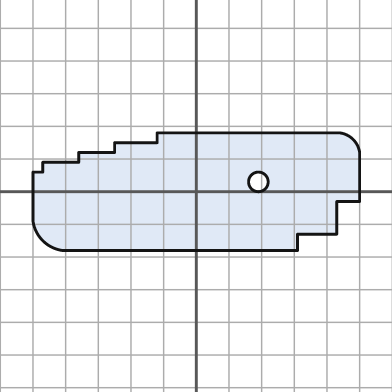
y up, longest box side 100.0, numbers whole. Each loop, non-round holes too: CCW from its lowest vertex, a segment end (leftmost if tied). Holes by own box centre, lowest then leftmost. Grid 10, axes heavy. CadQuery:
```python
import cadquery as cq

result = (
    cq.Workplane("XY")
    .moveTo(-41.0, -18.0)
    .lineTo(31.0, -18.0)
    .lineTo(31.0, -13.0)
    .lineTo(43.0, -13.0)
    .lineTo(43.0, -3.0)
    .lineTo(50.0, -3.0)
    .lineTo(50.0, 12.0)
    .threePointArc((48.0, 16.0), (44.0, 18.0))
    .lineTo(-12.0, 18.0)
    .lineTo(-12.0, 15.0)
    .lineTo(-25.0, 15.0)
    .lineTo(-25.0, 12.0)
    .lineTo(-36.0, 12.0)
    .lineTo(-36.0, 9.0)
    .lineTo(-47.0, 9.0)
    .lineTo(-47.0, 6.0)
    .lineTo(-50.0, 6.0)
    .lineTo(-50.0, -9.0)
    .threePointArc((-47.0, -15.0), (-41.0, -18.0))
    .close()
    .moveTo(19.0, 3.0)
    .circle(3.0)
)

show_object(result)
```